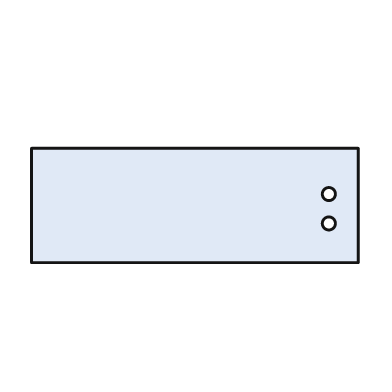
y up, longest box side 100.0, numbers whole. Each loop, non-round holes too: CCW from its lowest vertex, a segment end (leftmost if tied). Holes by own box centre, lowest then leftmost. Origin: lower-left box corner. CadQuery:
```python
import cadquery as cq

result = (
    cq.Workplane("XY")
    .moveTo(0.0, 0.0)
    .lineTo(100.0, 0.0)
    .lineTo(100.0, 35.0)
    .lineTo(0.0, 35.0)
    .close()
    .moveTo(91.0, 12.0)
    .circle(2.0)
    .moveTo(91.0, 21.0)
    .circle(2.0)
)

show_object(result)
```